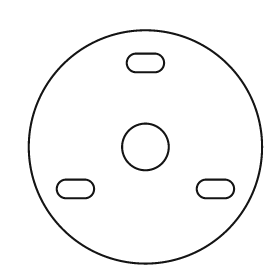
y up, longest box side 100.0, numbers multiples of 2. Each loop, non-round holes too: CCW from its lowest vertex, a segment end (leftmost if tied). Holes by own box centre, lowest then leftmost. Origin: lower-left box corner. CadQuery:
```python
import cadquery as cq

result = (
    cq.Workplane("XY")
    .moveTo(50.0, 50.0)
    .circle(50.0)
    .moveTo(16.0, 28.0)
    .lineTo(24.0, 28.0)
    .threePointArc((28.0, 32.0), (24.0, 36.0))
    .lineTo(16.0, 36.0)
    .threePointArc((12.0, 32.0), (16.0, 28.0))
    .close()
    .moveTo(76.0, 28.0)
    .lineTo(84.0, 28.0)
    .threePointArc((88.0, 32.0), (84.0, 36.0))
    .lineTo(76.0, 36.0)
    .threePointArc((72.0, 32.0), (76.0, 28.0))
    .close()
    .moveTo(50.0, 50.0)
    .circle(10.0)
    .moveTo(46.0, 82.0)
    .lineTo(54.0, 82.0)
    .threePointArc((58.0, 86.0), (54.0, 90.0))
    .lineTo(46.0, 90.0)
    .threePointArc((42.0, 86.0), (46.0, 82.0))
    .close()
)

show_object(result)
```